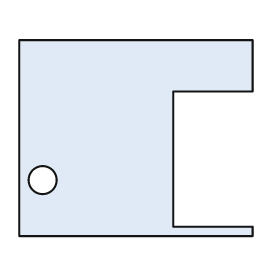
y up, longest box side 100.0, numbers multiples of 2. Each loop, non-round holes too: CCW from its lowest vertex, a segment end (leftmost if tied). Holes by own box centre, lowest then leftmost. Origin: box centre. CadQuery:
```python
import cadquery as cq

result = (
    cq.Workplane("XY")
    .moveTo(-50.0, -42.0)
    .lineTo(50.0, -42.0)
    .lineTo(50.0, -38.0)
    .lineTo(16.0, -38.0)
    .lineTo(16.0, 20.0)
    .lineTo(50.0, 20.0)
    .lineTo(50.0, 42.0)
    .lineTo(-50.0, 42.0)
    .close()
    .moveTo(-40.0, -18.0)
    .circle(6.0)
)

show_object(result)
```